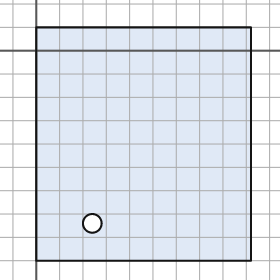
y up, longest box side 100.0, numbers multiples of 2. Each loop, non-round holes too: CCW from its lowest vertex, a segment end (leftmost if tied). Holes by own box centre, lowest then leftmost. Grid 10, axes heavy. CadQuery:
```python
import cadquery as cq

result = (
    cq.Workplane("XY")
    .moveTo(0.0, -90.0)
    .lineTo(92.0, -90.0)
    .lineTo(92.0, 10.0)
    .lineTo(0.0, 10.0)
    .close()
    .moveTo(24.0, -74.0)
    .circle(4.0)
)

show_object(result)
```